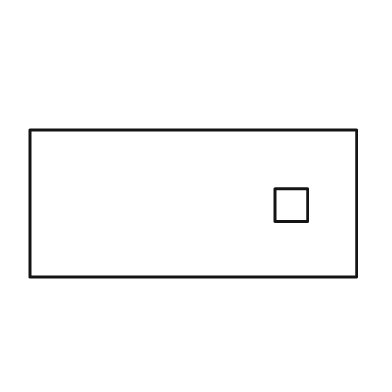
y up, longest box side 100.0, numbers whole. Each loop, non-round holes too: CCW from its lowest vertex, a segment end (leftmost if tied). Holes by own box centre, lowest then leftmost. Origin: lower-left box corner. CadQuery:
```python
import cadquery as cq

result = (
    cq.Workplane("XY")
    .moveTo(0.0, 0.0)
    .lineTo(100.0, 0.0)
    .lineTo(100.0, 45.0)
    .lineTo(0.0, 45.0)
    .close()
    .moveTo(75.0, 17.0)
    .lineTo(85.0, 17.0)
    .lineTo(85.0, 27.0)
    .lineTo(75.0, 27.0)
    .close()
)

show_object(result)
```